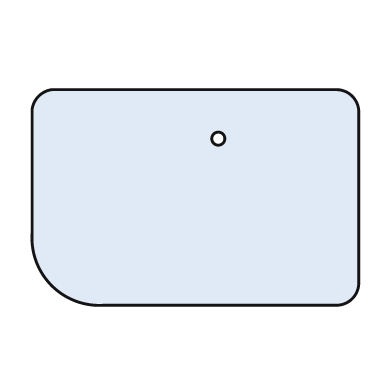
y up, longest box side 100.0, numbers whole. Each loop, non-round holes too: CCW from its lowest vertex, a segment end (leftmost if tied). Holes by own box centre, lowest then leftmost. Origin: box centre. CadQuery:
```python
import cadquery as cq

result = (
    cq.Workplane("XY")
    .moveTo(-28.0, -33.0)
    .lineTo(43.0, -33.0)
    .threePointArc((48.0, -31.0), (50.0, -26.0))
    .lineTo(50.0, 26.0)
    .threePointArc((48.0, 31.0), (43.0, 33.0))
    .lineTo(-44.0, 33.0)
    .threePointArc((-48.0, 31.0), (-50.0, 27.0))
    .lineTo(-50.0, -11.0)
    .threePointArc((-44.0, -27.0), (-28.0, -33.0))
    .close()
    .moveTo(7.0, 18.0)
    .circle(2.0)
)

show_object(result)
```